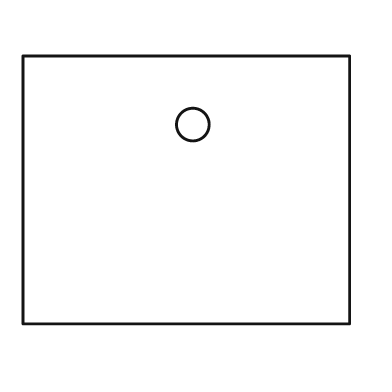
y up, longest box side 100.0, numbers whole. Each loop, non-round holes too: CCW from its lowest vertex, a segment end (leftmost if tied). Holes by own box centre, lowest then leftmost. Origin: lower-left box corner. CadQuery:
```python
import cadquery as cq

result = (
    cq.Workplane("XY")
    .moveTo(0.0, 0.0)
    .lineTo(100.0, 0.0)
    .lineTo(100.0, 82.0)
    .lineTo(0.0, 82.0)
    .close()
    .moveTo(52.0, 61.0)
    .circle(5.0)
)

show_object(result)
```